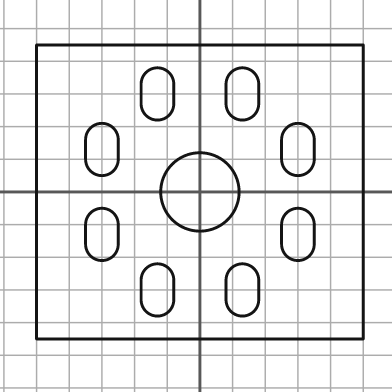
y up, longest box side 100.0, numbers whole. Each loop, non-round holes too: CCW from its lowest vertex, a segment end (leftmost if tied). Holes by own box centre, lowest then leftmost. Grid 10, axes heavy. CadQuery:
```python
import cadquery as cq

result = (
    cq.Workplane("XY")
    .moveTo(-50.0, -45.0)
    .lineTo(50.0, -45.0)
    .lineTo(50.0, 45.0)
    .lineTo(-50.0, 45.0)
    .close()
    .moveTo(-18.0, -33.0)
    .threePointArc((-13.0, -38.0), (-8.0, -33.0))
    .lineTo(-8.0, -27.0)
    .threePointArc((-13.0, -22.0), (-18.0, -27.0))
    .close()
    .moveTo(8.0, -33.0)
    .threePointArc((13.0, -38.0), (18.0, -33.0))
    .lineTo(18.0, -27.0)
    .threePointArc((13.0, -22.0), (8.0, -27.0))
    .close()
    .moveTo(-35.0, -16.0)
    .threePointArc((-30.0, -21.0), (-25.0, -16.0))
    .lineTo(-25.0, -10.0)
    .threePointArc((-30.0, -5.0), (-35.0, -10.0))
    .close()
    .moveTo(25.0, -16.0)
    .threePointArc((30.0, -21.0), (35.0, -16.0))
    .lineTo(35.0, -10.0)
    .threePointArc((30.0, -5.0), (25.0, -10.0))
    .close()
    .moveTo(0.0, 0.0)
    .circle(12.0)
    .moveTo(-35.0, 10.0)
    .threePointArc((-30.0, 5.0), (-25.0, 10.0))
    .lineTo(-25.0, 16.0)
    .threePointArc((-30.0, 21.0), (-35.0, 16.0))
    .close()
    .moveTo(25.0, 10.0)
    .threePointArc((30.0, 5.0), (35.0, 10.0))
    .lineTo(35.0, 16.0)
    .threePointArc((30.0, 21.0), (25.0, 16.0))
    .close()
    .moveTo(-18.0, 27.0)
    .threePointArc((-13.0, 22.0), (-8.0, 27.0))
    .lineTo(-8.0, 33.0)
    .threePointArc((-13.0, 38.0), (-18.0, 33.0))
    .close()
    .moveTo(8.0, 27.0)
    .threePointArc((13.0, 22.0), (18.0, 27.0))
    .lineTo(18.0, 33.0)
    .threePointArc((13.0, 38.0), (8.0, 33.0))
    .close()
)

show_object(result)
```